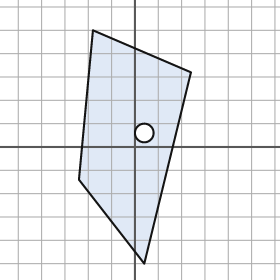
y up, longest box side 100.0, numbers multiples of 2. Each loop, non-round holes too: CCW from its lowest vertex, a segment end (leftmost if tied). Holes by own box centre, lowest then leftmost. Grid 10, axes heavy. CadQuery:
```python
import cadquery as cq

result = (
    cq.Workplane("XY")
    .moveTo(4.0, -50.0)
    .lineTo(24.0, 32.0)
    .lineTo(-18.0, 50.0)
    .lineTo(-24.0, -14.0)
    .close()
    .moveTo(4.0, 6.0)
    .circle(4.0)
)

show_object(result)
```